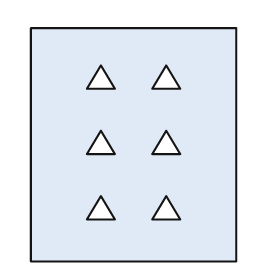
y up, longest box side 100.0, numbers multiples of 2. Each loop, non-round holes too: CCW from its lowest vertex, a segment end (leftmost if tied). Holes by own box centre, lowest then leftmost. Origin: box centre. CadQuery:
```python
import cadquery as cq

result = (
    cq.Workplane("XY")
    .moveTo(-44.0, -50.0)
    .lineTo(44.0, -50.0)
    .lineTo(44.0, 50.0)
    .lineTo(-44.0, 50.0)
    .close()
    .moveTo(-20.0, -32.0)
    .lineTo(-8.0, -32.0)
    .lineTo(-14.0, -22.0)
    .close()
    .moveTo(8.0, -32.0)
    .lineTo(20.0, -32.0)
    .lineTo(14.0, -22.0)
    .close()
    .moveTo(-20.0, -4.0)
    .lineTo(-8.0, -4.0)
    .lineTo(-14.0, 6.0)
    .close()
    .moveTo(8.0, -4.0)
    .lineTo(20.0, -4.0)
    .lineTo(14.0, 6.0)
    .close()
    .moveTo(-20.0, 24.0)
    .lineTo(-8.0, 24.0)
    .lineTo(-14.0, 34.0)
    .close()
    .moveTo(8.0, 24.0)
    .lineTo(20.0, 24.0)
    .lineTo(14.0, 34.0)
    .close()
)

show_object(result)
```